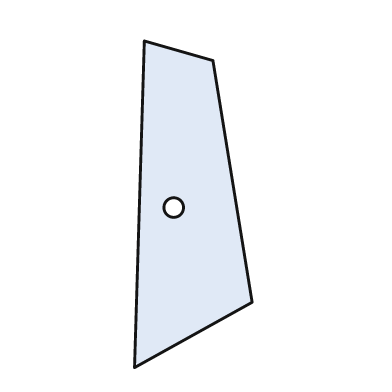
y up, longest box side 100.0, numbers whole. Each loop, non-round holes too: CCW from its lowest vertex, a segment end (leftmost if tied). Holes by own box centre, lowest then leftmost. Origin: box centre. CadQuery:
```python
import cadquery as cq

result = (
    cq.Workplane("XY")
    .moveTo(-18.0, -50.0)
    .lineTo(18.0, -30.0)
    .lineTo(6.0, 44.0)
    .lineTo(-15.0, 50.0)
    .close()
    .moveTo(-6.0, -1.0)
    .circle(3.0)
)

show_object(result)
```